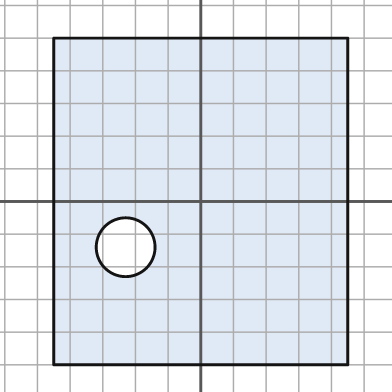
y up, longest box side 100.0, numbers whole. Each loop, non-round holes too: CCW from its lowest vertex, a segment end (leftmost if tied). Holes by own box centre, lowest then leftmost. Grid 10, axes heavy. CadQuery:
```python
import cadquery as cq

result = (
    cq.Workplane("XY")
    .moveTo(-45.0, -50.0)
    .lineTo(45.0, -50.0)
    .lineTo(45.0, 50.0)
    .lineTo(-45.0, 50.0)
    .close()
    .moveTo(-23.0, -14.0)
    .circle(9.0)
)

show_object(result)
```